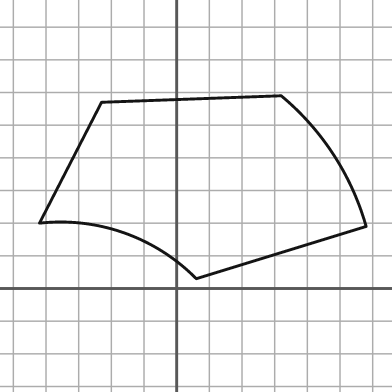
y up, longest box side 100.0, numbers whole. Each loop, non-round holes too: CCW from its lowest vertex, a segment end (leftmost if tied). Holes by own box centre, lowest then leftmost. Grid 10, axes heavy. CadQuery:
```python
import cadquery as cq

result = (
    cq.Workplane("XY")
    .moveTo(6.0, 3.0)
    .lineTo(58.0, 19.0)
    .threePointArc((48.0, 41.0), (32.0, 59.0))
    .lineTo(-23.0, 57.0)
    .lineTo(-42.0, 20.0)
    .threePointArc((-16.0, 17.0), (6.0, 3.0))
    .close()
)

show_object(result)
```